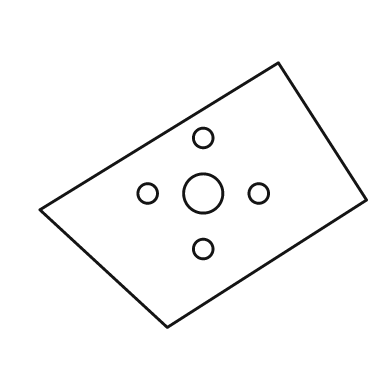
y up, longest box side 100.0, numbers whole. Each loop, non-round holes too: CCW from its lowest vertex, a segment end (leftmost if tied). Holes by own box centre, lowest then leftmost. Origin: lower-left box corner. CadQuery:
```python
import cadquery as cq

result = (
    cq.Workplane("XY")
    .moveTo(39.0, 0.0)
    .lineTo(100.0, 39.0)
    .lineTo(73.0, 81.0)
    .lineTo(0.0, 36.0)
    .close()
    .moveTo(50.0, 24.0)
    .circle(3.0)
    .moveTo(33.0, 41.0)
    .circle(3.0)
    .moveTo(50.0, 41.0)
    .circle(6.0)
    .moveTo(67.0, 41.0)
    .circle(3.0)
    .moveTo(50.0, 58.0)
    .circle(3.0)
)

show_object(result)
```